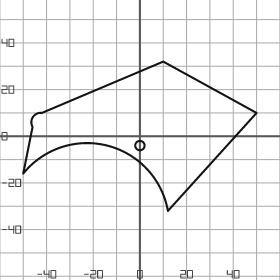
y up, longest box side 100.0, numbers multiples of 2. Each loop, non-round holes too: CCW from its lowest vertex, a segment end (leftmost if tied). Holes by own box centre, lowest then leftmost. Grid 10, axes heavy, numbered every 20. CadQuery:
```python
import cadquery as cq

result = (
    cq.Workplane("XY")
    .moveTo(12.0, -32.0)
    .lineTo(50.0, 10.0)
    .lineTo(10.0, 32.0)
    .lineTo(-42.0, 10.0)
    .threePointArc((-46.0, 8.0), (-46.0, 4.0))
    .lineTo(-50.0, -16.0)
    .threePointArc((-14.0, -4.0), (12.0, -32.0))
    .close()
    .moveTo(0.0, -4.0)
    .circle(2.0)
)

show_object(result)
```